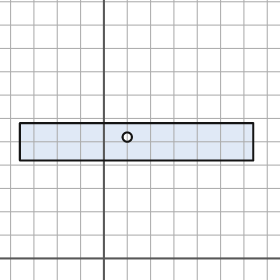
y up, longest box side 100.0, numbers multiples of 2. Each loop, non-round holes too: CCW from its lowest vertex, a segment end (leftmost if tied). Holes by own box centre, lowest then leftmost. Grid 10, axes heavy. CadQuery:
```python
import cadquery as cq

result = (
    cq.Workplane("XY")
    .moveTo(-36.0, 42.0)
    .lineTo(64.0, 42.0)
    .lineTo(64.0, 58.0)
    .lineTo(-36.0, 58.0)
    .close()
    .moveTo(10.0, 52.0)
    .circle(2.0)
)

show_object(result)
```